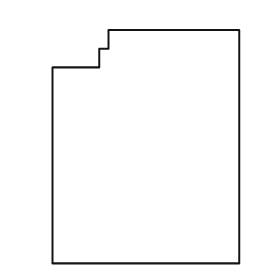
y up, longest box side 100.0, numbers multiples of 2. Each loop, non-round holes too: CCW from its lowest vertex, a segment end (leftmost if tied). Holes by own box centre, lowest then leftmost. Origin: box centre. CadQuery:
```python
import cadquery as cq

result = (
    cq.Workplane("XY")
    .moveTo(-40.0, -50.0)
    .lineTo(40.0, -50.0)
    .lineTo(40.0, 50.0)
    .lineTo(-16.0, 50.0)
    .lineTo(-16.0, 42.0)
    .lineTo(-20.0, 42.0)
    .lineTo(-20.0, 34.0)
    .lineTo(-40.0, 34.0)
    .close()
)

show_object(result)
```